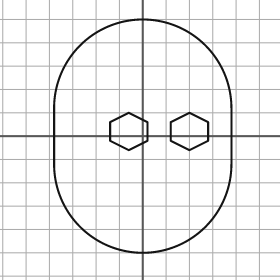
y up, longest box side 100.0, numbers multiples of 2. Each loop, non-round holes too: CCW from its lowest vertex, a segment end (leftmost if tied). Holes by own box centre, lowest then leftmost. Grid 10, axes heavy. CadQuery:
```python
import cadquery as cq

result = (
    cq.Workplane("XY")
    .moveTo(-38.0, -12.0)
    .threePointArc((0.0, -50.0), (38.0, -12.0))
    .lineTo(38.0, 12.0)
    .threePointArc((0.0, 50.0), (-38.0, 12.0))
    .close()
    .moveTo(-6.0, -6.0)
    .lineTo(2.0, -2.0)
    .lineTo(2.0, 6.0)
    .lineTo(-6.0, 10.0)
    .lineTo(-14.0, 6.0)
    .lineTo(-14.0, -2.0)
    .close()
    .moveTo(20.0, -6.0)
    .lineTo(28.0, -2.0)
    .lineTo(28.0, 6.0)
    .lineTo(20.0, 10.0)
    .lineTo(12.0, 6.0)
    .lineTo(12.0, -2.0)
    .close()
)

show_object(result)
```